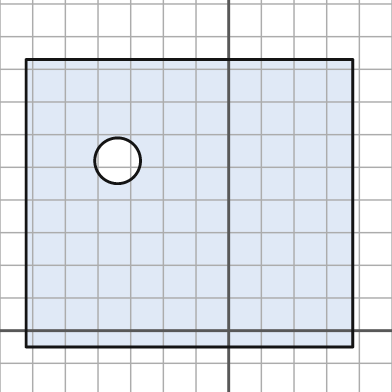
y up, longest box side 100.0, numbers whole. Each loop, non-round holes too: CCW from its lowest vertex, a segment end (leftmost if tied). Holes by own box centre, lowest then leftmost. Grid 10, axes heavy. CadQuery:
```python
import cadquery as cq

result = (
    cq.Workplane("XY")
    .moveTo(-62.0, -5.0)
    .lineTo(38.0, -5.0)
    .lineTo(38.0, 83.0)
    .lineTo(-62.0, 83.0)
    .close()
    .moveTo(-34.0, 52.0)
    .circle(7.0)
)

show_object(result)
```